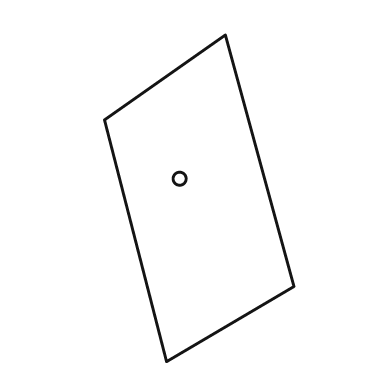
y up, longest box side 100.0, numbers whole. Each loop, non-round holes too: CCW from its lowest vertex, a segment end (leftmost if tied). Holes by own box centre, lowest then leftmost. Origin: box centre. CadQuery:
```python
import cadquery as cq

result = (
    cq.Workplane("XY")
    .moveTo(-10.0, -50.0)
    .lineTo(29.0, -27.0)
    .lineTo(8.0, 50.0)
    .lineTo(-29.0, 24.0)
    .close()
    .moveTo(-6.0, 6.0)
    .circle(2.0)
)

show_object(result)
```